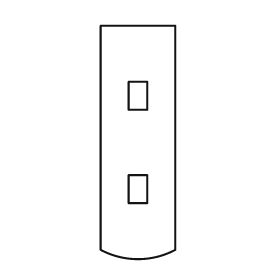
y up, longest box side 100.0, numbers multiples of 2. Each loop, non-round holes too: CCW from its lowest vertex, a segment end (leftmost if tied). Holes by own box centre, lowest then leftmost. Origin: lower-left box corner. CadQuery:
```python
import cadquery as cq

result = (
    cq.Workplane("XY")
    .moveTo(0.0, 4.0)
    .threePointArc((16.0, 0.0), (32.0, 4.0))
    .lineTo(32.0, 100.0)
    .lineTo(0.0, 100.0)
    .close()
    .moveTo(12.0, 24.0)
    .lineTo(20.0, 24.0)
    .lineTo(20.0, 36.0)
    .lineTo(12.0, 36.0)
    .close()
    .moveTo(12.0, 64.0)
    .lineTo(20.0, 64.0)
    .lineTo(20.0, 76.0)
    .lineTo(12.0, 76.0)
    .close()
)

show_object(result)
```